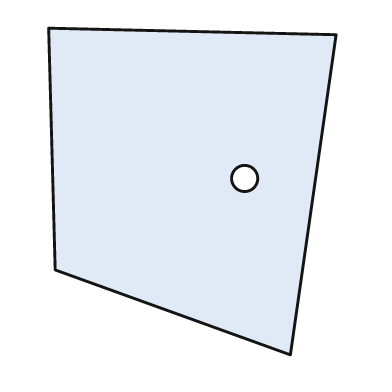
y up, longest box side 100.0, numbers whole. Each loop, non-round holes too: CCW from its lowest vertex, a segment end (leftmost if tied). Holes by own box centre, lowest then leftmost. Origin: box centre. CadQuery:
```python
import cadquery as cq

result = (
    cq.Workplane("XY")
    .moveTo(30.0, -50.0)
    .lineTo(44.0, 48.0)
    .lineTo(-44.0, 50.0)
    .lineTo(-42.0, -24.0)
    .close()
    .moveTo(16.0, 4.0)
    .circle(4.0)
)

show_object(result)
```